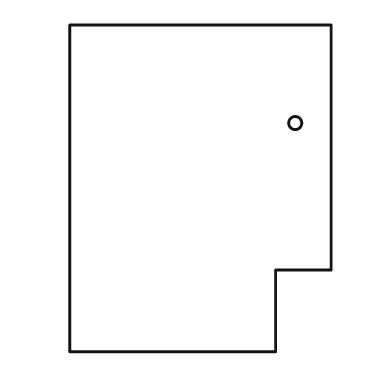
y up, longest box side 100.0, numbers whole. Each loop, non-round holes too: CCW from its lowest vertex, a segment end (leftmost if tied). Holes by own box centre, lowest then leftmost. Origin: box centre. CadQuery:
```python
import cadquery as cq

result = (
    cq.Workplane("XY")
    .moveTo(-40.0, -50.0)
    .lineTo(23.0, -50.0)
    .lineTo(23.0, -25.0)
    .lineTo(40.0, -25.0)
    .lineTo(40.0, 50.0)
    .lineTo(-40.0, 50.0)
    .close()
    .moveTo(29.0, 20.0)
    .circle(2.0)
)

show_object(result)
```